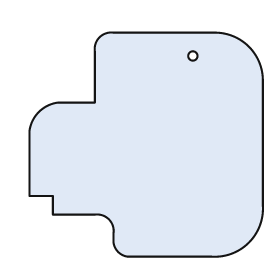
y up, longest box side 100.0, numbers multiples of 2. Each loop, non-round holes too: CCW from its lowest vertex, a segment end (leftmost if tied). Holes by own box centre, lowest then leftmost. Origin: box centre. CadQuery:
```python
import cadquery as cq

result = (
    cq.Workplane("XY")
    .moveTo(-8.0, -48.0)
    .lineTo(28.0, -48.0)
    .threePointArc((44.0, -42.0), (50.0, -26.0))
    .lineTo(50.0, 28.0)
    .threePointArc((44.0, 42.0), (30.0, 48.0))
    .lineTo(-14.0, 48.0)
    .threePointArc((-20.0, 46.0), (-22.0, 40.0))
    .lineTo(-22.0, 18.0)
    .lineTo(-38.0, 18.0)
    .threePointArc((-46.0, 14.0), (-50.0, 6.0))
    .lineTo(-50.0, -22.0)
    .lineTo(-40.0, -22.0)
    .lineTo(-40.0, -30.0)
    .lineTo(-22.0, -30.0)
    .threePointArc((-16.0, -32.0), (-14.0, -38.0))
    .lineTo(-14.0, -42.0)
    .threePointArc((-12.0, -46.0), (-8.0, -48.0))
    .close()
    .moveTo(20.0, 38.0)
    .circle(2.0)
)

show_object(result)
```